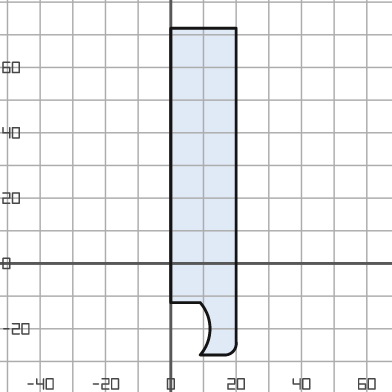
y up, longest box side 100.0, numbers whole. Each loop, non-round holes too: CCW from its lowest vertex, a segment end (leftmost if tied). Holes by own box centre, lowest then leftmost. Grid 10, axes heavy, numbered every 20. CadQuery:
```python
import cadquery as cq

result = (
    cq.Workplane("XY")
    .moveTo(9.0, -28.0)
    .lineTo(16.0, -28.0)
    .threePointArc((19.0, -27.0), (20.0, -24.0))
    .lineTo(20.0, 72.0)
    .lineTo(0.0, 72.0)
    .lineTo(0.0, -12.0)
    .lineTo(9.0, -12.0)
    .threePointArc((12.0, -20.0), (9.0, -28.0))
    .close()
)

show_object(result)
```